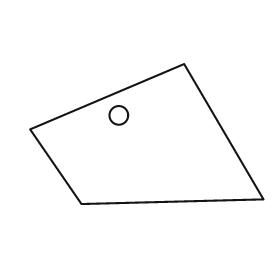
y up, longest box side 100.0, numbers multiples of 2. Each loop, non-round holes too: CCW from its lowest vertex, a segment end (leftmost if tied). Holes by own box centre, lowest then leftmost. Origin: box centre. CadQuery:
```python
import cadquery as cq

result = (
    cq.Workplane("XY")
    .moveTo(-28.0, -30.0)
    .lineTo(50.0, -28.0)
    .lineTo(16.0, 30.0)
    .lineTo(-50.0, 2.0)
    .close()
    .moveTo(-12.0, 8.0)
    .circle(4.0)
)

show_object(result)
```